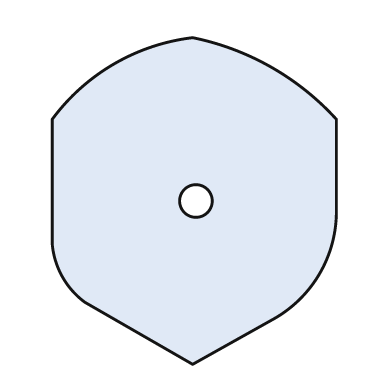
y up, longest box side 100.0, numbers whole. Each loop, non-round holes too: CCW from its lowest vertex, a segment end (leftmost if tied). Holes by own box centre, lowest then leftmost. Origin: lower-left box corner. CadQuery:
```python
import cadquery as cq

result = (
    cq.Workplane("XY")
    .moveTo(43.0, 0.0)
    .lineTo(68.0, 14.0)
    .threePointArc((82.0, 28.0), (87.0, 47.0))
    .lineTo(87.0, 75.0)
    .threePointArc((67.0, 91.0), (43.0, 100.0))
    .threePointArc((19.0, 92.0), (0.0, 75.0))
    .lineTo(0.0, 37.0)
    .threePointArc((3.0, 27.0), (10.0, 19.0))
    .close()
    .moveTo(44.0, 50.0)
    .circle(5.0)
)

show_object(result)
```